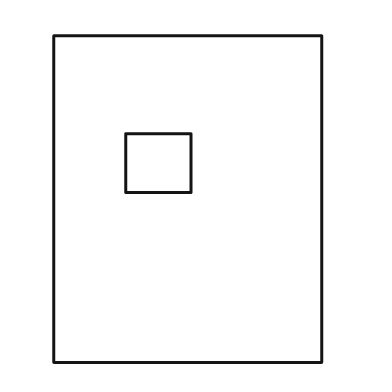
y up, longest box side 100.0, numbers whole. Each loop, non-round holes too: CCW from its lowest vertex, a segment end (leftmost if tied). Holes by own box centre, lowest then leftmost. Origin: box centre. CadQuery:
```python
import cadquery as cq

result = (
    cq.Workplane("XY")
    .moveTo(-41.0, -50.0)
    .lineTo(41.0, -50.0)
    .lineTo(41.0, 50.0)
    .lineTo(-41.0, 50.0)
    .close()
    .moveTo(-19.0, 2.0)
    .lineTo(1.0, 2.0)
    .lineTo(1.0, 20.0)
    .lineTo(-19.0, 20.0)
    .close()
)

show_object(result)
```